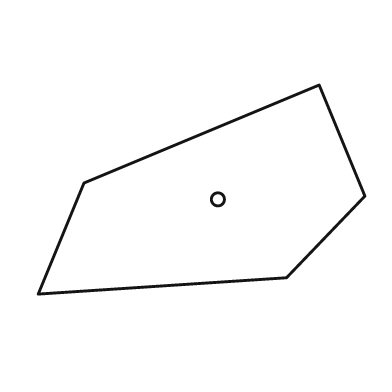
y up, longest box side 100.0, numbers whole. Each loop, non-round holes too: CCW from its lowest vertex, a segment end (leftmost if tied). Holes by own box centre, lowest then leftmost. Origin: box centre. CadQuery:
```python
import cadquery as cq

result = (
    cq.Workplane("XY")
    .moveTo(-50.0, -32.0)
    .lineTo(26.0, -27.0)
    .lineTo(50.0, -2.0)
    .lineTo(36.0, 32.0)
    .lineTo(-36.0, 2.0)
    .close()
    .moveTo(5.0, -3.0)
    .circle(2.0)
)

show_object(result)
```